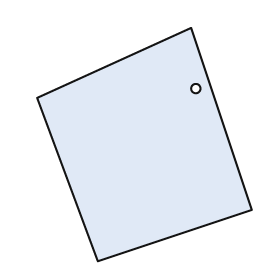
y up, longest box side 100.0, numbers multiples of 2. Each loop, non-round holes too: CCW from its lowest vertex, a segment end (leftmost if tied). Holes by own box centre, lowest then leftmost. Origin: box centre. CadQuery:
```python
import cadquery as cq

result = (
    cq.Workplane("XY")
    .moveTo(-20.0, -50.0)
    .lineTo(46.0, -28.0)
    .lineTo(20.0, 50.0)
    .lineTo(-46.0, 20.0)
    .close()
    .moveTo(22.0, 24.0)
    .circle(2.0)
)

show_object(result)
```